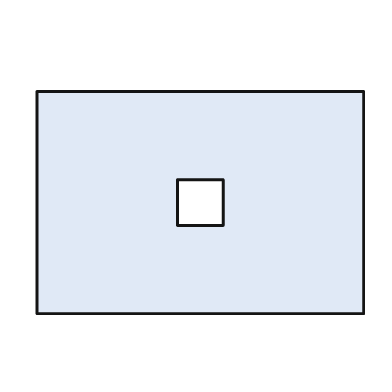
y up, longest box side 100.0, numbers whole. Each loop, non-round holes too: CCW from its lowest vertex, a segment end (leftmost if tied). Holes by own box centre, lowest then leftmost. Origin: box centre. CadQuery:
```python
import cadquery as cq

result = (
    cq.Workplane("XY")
    .moveTo(-50.0, -34.0)
    .lineTo(50.0, -34.0)
    .lineTo(50.0, 34.0)
    .lineTo(-50.0, 34.0)
    .close()
    .moveTo(-7.0, -7.0)
    .lineTo(7.0, -7.0)
    .lineTo(7.0, 7.0)
    .lineTo(-7.0, 7.0)
    .close()
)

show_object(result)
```